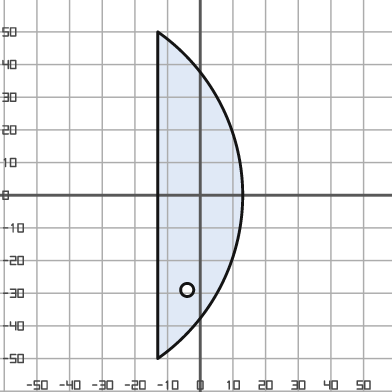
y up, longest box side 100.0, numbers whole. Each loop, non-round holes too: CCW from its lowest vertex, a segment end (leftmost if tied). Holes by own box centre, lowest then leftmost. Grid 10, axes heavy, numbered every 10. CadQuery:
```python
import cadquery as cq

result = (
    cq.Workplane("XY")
    .moveTo(-13.0, -50.0)
    .threePointArc((13.0, 0.0), (-13.0, 50.0))
    .close()
    .moveTo(-4.0, -29.0)
    .circle(2.0)
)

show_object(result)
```